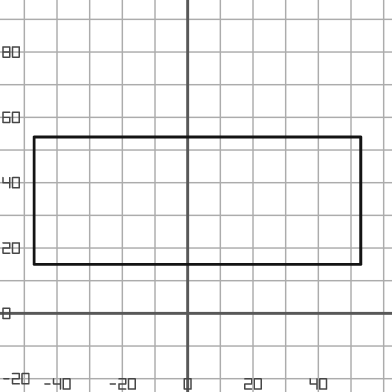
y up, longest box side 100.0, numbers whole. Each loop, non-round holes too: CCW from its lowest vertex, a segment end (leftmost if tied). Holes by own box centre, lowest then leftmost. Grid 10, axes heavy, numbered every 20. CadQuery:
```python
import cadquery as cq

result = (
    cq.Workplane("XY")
    .moveTo(-47.0, 15.0)
    .lineTo(53.0, 15.0)
    .lineTo(53.0, 54.0)
    .lineTo(-47.0, 54.0)
    .close()
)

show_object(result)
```